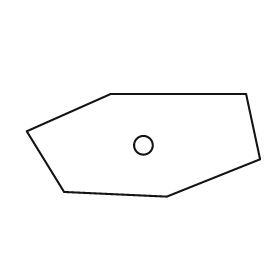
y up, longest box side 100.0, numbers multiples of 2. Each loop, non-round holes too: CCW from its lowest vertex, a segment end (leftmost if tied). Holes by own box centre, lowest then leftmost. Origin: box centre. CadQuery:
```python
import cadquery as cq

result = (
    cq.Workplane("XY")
    .moveTo(10.0, -22.0)
    .lineTo(50.0, -6.0)
    .lineTo(44.0, 22.0)
    .lineTo(-14.0, 22.0)
    .lineTo(-50.0, 6.0)
    .lineTo(-34.0, -20.0)
    .close()
    .moveTo(0.0, 0.0)
    .circle(4.0)
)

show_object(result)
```